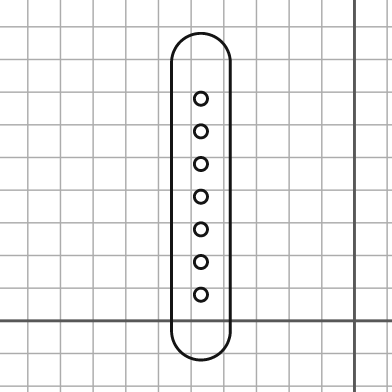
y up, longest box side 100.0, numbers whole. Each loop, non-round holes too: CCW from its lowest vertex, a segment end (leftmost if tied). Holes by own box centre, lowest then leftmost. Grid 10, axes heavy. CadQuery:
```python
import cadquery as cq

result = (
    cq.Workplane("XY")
    .moveTo(-56.0, -3.0)
    .threePointArc((-47.0, -12.0), (-38.0, -3.0))
    .lineTo(-38.0, 79.0)
    .threePointArc((-47.0, 88.0), (-56.0, 79.0))
    .close()
    .moveTo(-47.0, 8.0)
    .circle(2.0)
    .moveTo(-47.0, 18.0)
    .circle(2.0)
    .moveTo(-47.0, 28.0)
    .circle(2.0)
    .moveTo(-47.0, 38.0)
    .circle(2.0)
    .moveTo(-47.0, 48.0)
    .circle(2.0)
    .moveTo(-47.0, 58.0)
    .circle(2.0)
    .moveTo(-47.0, 68.0)
    .circle(2.0)
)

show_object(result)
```